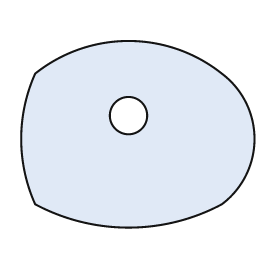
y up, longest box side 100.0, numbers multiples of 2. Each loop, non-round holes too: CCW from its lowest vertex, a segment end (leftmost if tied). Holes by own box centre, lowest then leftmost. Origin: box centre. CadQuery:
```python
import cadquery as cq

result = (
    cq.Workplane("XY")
    .moveTo(-44.0, -30.0)
    .threePointArc((-4.0, -40.0), (36.0, -30.0))
    .threePointArc((50.0, -2.0), (36.0, 26.0))
    .threePointArc((-4.0, 40.0), (-44.0, 26.0))
    .threePointArc((-50.0, -2.0), (-44.0, -30.0))
    .close()
    .moveTo(-4.0, 8.0)
    .circle(8.0)
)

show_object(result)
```